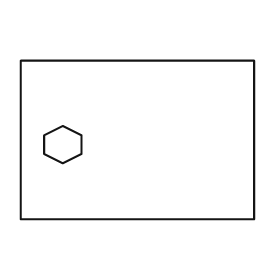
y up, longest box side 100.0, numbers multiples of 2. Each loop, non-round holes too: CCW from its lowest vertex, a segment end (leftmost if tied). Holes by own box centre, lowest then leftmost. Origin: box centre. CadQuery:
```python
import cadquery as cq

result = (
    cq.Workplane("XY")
    .moveTo(-50.0, -34.0)
    .lineTo(50.0, -34.0)
    .lineTo(50.0, 34.0)
    .lineTo(-50.0, 34.0)
    .close()
    .moveTo(-32.0, -10.0)
    .lineTo(-24.0, -6.0)
    .lineTo(-24.0, 2.0)
    .lineTo(-32.0, 6.0)
    .lineTo(-40.0, 2.0)
    .lineTo(-40.0, -6.0)
    .close()
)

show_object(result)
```